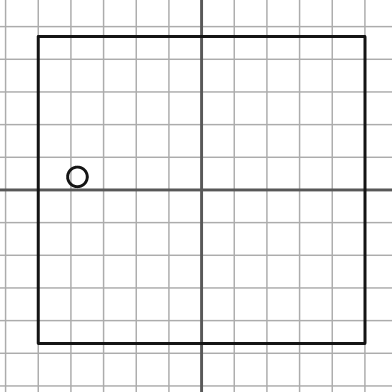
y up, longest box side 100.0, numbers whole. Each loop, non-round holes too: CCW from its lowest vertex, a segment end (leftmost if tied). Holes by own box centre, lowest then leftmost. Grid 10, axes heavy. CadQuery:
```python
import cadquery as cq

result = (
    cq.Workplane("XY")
    .moveTo(-50.0, -47.0)
    .lineTo(50.0, -47.0)
    .lineTo(50.0, 47.0)
    .lineTo(-50.0, 47.0)
    .close()
    .moveTo(-38.0, 4.0)
    .circle(3.0)
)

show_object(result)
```